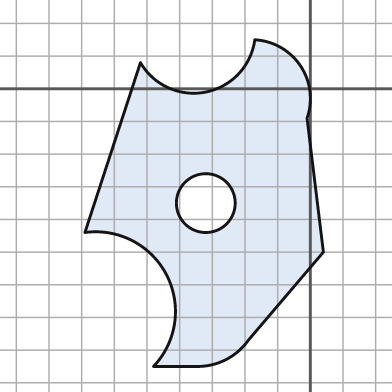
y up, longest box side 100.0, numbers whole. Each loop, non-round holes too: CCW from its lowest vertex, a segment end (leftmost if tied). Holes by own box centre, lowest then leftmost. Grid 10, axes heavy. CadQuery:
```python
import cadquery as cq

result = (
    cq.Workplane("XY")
    .moveTo(-48.0, -85.0)
    .lineTo(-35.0, -85.0)
    .threePointArc((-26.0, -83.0), (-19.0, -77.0))
    .lineTo(4.0, -50.0)
    .lineTo(-1.0, -9.0)
    .threePointArc((-3.0, 7.0), (-17.0, 15.0))
    .threePointArc((-32.0, -1.0), (-52.0, 8.0))
    .lineTo(-69.0, -44.0)
    .threePointArc((-44.0, -57.0), (-48.0, -85.0))
    .close()
    .moveTo(-32.0, -35.0)
    .circle(9.0)
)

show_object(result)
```